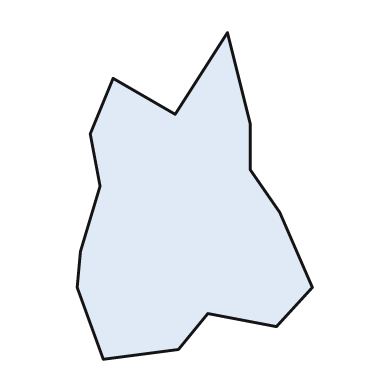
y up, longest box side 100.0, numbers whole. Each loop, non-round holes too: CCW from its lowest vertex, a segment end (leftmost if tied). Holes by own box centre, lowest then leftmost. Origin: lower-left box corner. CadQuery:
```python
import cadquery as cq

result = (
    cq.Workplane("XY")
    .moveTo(8.0, 0.0)
    .lineTo(31.0, 3.0)
    .lineTo(40.0, 14.0)
    .lineTo(61.0, 10.0)
    .lineTo(72.0, 22.0)
    .lineTo(62.0, 45.0)
    .lineTo(53.0, 58.0)
    .lineTo(53.0, 72.0)
    .lineTo(46.0, 100.0)
    .lineTo(30.0, 75.0)
    .lineTo(11.0, 86.0)
    .lineTo(4.0, 69.0)
    .lineTo(7.0, 53.0)
    .lineTo(1.0, 33.0)
    .lineTo(0.0, 22.0)
    .close()
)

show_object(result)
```